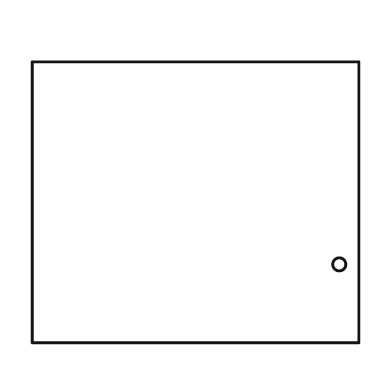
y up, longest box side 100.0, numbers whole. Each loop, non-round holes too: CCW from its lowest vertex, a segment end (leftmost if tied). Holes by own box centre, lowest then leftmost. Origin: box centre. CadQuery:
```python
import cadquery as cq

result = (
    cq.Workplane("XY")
    .moveTo(-50.0, -43.0)
    .lineTo(50.0, -43.0)
    .lineTo(50.0, 43.0)
    .lineTo(-50.0, 43.0)
    .close()
    .moveTo(44.0, -19.0)
    .circle(2.0)
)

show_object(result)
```